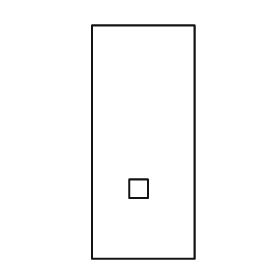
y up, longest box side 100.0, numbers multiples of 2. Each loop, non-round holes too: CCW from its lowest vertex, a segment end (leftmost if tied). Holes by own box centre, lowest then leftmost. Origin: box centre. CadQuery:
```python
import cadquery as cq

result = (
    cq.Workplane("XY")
    .moveTo(-22.0, -50.0)
    .lineTo(22.0, -50.0)
    .lineTo(22.0, 50.0)
    .lineTo(-22.0, 50.0)
    .close()
    .moveTo(-6.0, -24.0)
    .lineTo(2.0, -24.0)
    .lineTo(2.0, -16.0)
    .lineTo(-6.0, -16.0)
    .close()
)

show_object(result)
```